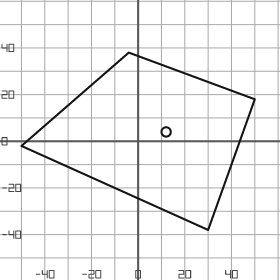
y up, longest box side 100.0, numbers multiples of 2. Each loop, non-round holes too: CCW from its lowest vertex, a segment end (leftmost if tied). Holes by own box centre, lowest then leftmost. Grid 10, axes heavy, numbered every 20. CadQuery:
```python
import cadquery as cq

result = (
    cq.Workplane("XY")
    .moveTo(30.0, -38.0)
    .lineTo(50.0, 18.0)
    .lineTo(-4.0, 38.0)
    .lineTo(-50.0, -2.0)
    .close()
    .moveTo(12.0, 4.0)
    .circle(2.0)
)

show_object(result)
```